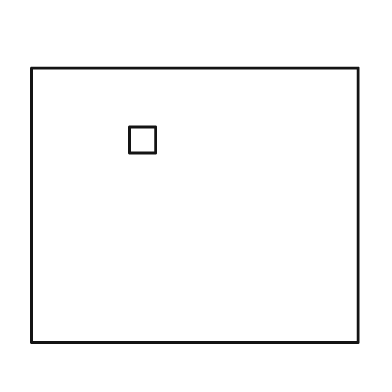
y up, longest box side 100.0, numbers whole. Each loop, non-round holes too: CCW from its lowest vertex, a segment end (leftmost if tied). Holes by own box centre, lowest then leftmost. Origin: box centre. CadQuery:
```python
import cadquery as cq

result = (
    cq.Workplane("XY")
    .moveTo(-50.0, -42.0)
    .lineTo(50.0, -42.0)
    .lineTo(50.0, 42.0)
    .lineTo(-50.0, 42.0)
    .close()
    .moveTo(-20.0, 16.0)
    .lineTo(-12.0, 16.0)
    .lineTo(-12.0, 24.0)
    .lineTo(-20.0, 24.0)
    .close()
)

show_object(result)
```